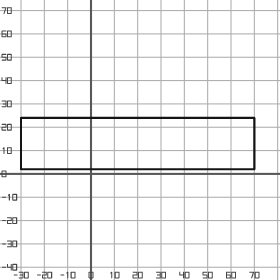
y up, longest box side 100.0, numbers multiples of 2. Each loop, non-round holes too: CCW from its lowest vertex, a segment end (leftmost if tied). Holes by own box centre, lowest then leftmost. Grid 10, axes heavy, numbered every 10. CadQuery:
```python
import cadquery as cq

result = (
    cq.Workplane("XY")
    .moveTo(-30.0, 2.0)
    .lineTo(70.0, 2.0)
    .lineTo(70.0, 24.0)
    .lineTo(-30.0, 24.0)
    .close()
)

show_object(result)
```